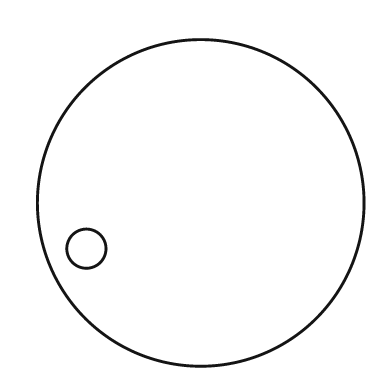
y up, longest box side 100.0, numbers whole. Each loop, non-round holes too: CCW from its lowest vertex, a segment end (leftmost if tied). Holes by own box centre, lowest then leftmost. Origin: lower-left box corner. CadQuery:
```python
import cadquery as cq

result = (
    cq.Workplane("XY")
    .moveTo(50.0, 50.0)
    .circle(50.0)
    .moveTo(15.0, 36.0)
    .circle(6.0)
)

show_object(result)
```